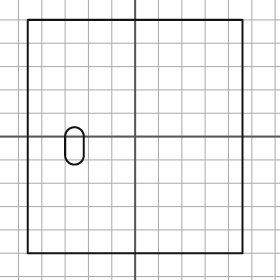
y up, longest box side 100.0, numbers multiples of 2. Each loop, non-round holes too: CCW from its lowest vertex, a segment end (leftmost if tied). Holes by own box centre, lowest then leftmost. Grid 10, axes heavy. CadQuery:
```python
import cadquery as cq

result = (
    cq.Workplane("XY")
    .moveTo(-46.0, -50.0)
    .lineTo(46.0, -50.0)
    .lineTo(46.0, 50.0)
    .lineTo(-46.0, 50.0)
    .close()
    .moveTo(-30.0, -8.0)
    .threePointArc((-26.0, -12.0), (-22.0, -8.0))
    .lineTo(-22.0, 0.0)
    .threePointArc((-26.0, 4.0), (-30.0, 0.0))
    .close()
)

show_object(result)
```